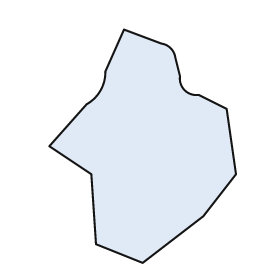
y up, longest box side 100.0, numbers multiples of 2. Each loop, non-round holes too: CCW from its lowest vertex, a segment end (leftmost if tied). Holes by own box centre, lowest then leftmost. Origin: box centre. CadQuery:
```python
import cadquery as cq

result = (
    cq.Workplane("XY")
    .moveTo(0.0, -50.0)
    .lineTo(26.0, -30.0)
    .lineTo(40.0, -12.0)
    .lineTo(36.0, 16.0)
    .lineTo(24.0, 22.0)
    .threePointArc((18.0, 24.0), (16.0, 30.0))
    .lineTo(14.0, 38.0)
    .threePointArc((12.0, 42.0), (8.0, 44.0))
    .lineTo(-8.0, 50.0)
    .lineTo(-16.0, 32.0)
    .threePointArc((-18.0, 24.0), (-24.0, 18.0))
    .lineTo(-40.0, 0.0)
    .lineTo(-22.0, -12.0)
    .lineTo(-20.0, -42.0)
    .close()
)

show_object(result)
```